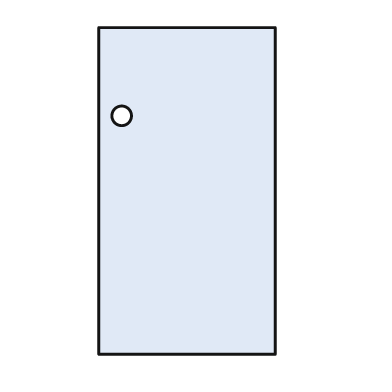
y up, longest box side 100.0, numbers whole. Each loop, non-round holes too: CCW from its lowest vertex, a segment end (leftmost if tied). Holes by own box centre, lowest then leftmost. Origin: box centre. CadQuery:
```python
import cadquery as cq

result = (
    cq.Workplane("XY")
    .moveTo(-27.0, -50.0)
    .lineTo(27.0, -50.0)
    .lineTo(27.0, 50.0)
    .lineTo(-27.0, 50.0)
    .close()
    .moveTo(-20.0, 23.0)
    .circle(3.0)
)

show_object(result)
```